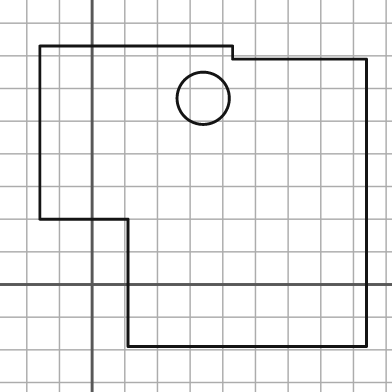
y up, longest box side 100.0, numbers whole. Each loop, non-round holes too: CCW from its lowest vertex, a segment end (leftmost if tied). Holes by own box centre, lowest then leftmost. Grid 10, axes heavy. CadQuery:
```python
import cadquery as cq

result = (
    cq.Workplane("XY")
    .moveTo(11.0, -19.0)
    .lineTo(84.0, -19.0)
    .lineTo(84.0, 69.0)
    .lineTo(43.0, 69.0)
    .lineTo(43.0, 73.0)
    .lineTo(-16.0, 73.0)
    .lineTo(-16.0, 20.0)
    .lineTo(11.0, 20.0)
    .close()
    .moveTo(34.0, 57.0)
    .circle(8.0)
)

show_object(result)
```